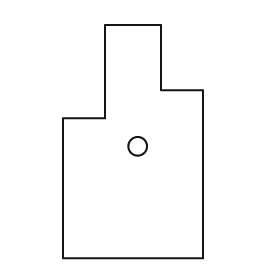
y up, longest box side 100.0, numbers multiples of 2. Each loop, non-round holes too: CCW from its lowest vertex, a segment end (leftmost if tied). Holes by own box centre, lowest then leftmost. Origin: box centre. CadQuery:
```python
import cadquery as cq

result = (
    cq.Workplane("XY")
    .moveTo(-30.0, -50.0)
    .lineTo(30.0, -50.0)
    .lineTo(30.0, 22.0)
    .lineTo(12.0, 22.0)
    .lineTo(12.0, 50.0)
    .lineTo(-12.0, 50.0)
    .lineTo(-12.0, 10.0)
    .lineTo(-30.0, 10.0)
    .close()
    .moveTo(2.0, -2.0)
    .circle(4.0)
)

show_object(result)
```